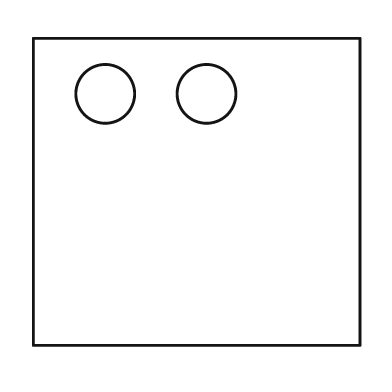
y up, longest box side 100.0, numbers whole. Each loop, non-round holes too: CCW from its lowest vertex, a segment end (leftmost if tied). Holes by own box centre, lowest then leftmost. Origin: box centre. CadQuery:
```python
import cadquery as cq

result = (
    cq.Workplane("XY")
    .moveTo(-50.0, -47.0)
    .lineTo(50.0, -47.0)
    .lineTo(50.0, 47.0)
    .lineTo(-50.0, 47.0)
    .close()
    .moveTo(-28.0, 30.0)
    .circle(9.0)
    .moveTo(3.0, 30.0)
    .circle(9.0)
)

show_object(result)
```